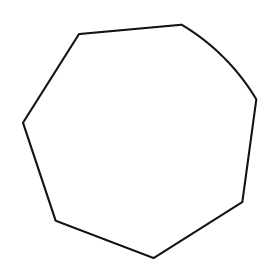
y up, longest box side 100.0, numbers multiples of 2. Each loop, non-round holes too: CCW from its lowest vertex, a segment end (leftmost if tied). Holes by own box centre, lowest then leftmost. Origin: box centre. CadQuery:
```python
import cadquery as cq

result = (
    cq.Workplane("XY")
    .moveTo(6.0, -50.0)
    .lineTo(44.0, -26.0)
    .lineTo(50.0, 18.0)
    .threePointArc((36.0, 36.0), (18.0, 50.0))
    .lineTo(-26.0, 46.0)
    .lineTo(-50.0, 8.0)
    .lineTo(-36.0, -34.0)
    .close()
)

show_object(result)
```